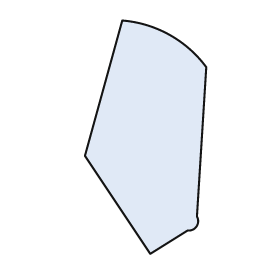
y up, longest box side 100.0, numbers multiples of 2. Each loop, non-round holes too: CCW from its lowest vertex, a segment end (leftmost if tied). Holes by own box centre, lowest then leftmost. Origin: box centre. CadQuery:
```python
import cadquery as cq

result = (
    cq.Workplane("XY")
    .moveTo(2.0, -50.0)
    .lineTo(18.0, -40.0)
    .threePointArc((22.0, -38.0), (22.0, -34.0))
    .lineTo(26.0, 30.0)
    .threePointArc((10.0, 44.0), (-10.0, 50.0))
    .lineTo(-26.0, -8.0)
    .close()
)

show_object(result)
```